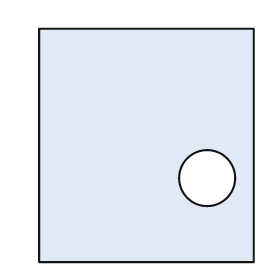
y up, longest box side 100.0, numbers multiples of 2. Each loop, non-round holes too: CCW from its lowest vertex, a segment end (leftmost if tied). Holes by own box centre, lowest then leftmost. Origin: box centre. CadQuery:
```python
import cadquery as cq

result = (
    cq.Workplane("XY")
    .moveTo(-46.0, -50.0)
    .lineTo(46.0, -50.0)
    .lineTo(46.0, 50.0)
    .lineTo(-46.0, 50.0)
    .close()
    .moveTo(26.0, -14.0)
    .circle(12.0)
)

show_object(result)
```